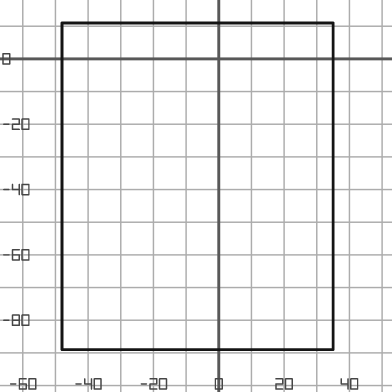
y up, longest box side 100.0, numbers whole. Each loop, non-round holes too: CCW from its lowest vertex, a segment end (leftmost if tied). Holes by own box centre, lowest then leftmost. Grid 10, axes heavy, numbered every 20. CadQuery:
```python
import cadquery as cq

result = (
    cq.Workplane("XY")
    .moveTo(-48.0, -89.0)
    .lineTo(35.0, -89.0)
    .lineTo(35.0, 11.0)
    .lineTo(-48.0, 11.0)
    .close()
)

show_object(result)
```